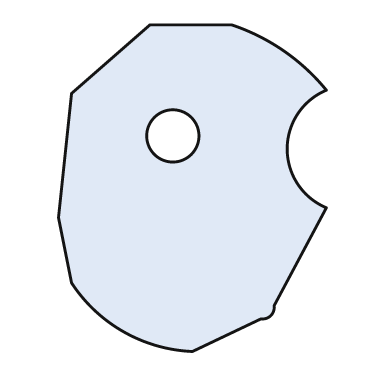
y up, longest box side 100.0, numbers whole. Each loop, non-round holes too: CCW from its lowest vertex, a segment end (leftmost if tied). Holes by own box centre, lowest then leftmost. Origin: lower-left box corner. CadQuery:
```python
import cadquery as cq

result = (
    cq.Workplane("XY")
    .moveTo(41.0, 0.0)
    .lineTo(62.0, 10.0)
    .threePointArc((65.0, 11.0), (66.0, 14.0))
    .lineTo(82.0, 44.0)
    .threePointArc((70.0, 62.0), (82.0, 80.0))
    .threePointArc((69.0, 92.0), (53.0, 100.0))
    .lineTo(28.0, 100.0)
    .lineTo(4.0, 79.0)
    .lineTo(0.0, 41.0)
    .lineTo(4.0, 21.0)
    .threePointArc((20.0, 6.0), (41.0, 0.0))
    .close()
    .moveTo(35.0, 66.0)
    .circle(8.0)
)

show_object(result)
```